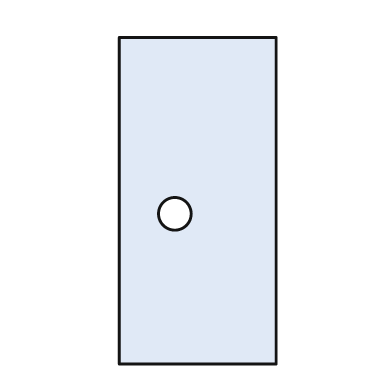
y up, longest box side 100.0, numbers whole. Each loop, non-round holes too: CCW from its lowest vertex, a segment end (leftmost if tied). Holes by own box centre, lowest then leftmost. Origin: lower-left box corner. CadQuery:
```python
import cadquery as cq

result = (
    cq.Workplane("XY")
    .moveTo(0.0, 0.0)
    .lineTo(48.0, 0.0)
    .lineTo(48.0, 100.0)
    .lineTo(0.0, 100.0)
    .close()
    .moveTo(17.0, 46.0)
    .circle(5.0)
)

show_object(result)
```